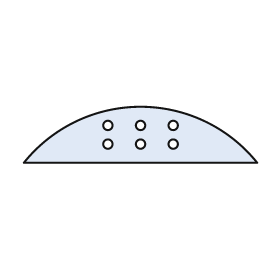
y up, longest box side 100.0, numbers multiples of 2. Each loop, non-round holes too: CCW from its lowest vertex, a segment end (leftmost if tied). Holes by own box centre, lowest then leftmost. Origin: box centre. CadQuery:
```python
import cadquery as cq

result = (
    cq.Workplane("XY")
    .moveTo(-50.0, -12.0)
    .lineTo(50.0, -12.0)
    .threePointArc((0.0, 12.0), (-50.0, -12.0))
    .close()
    .moveTo(-14.0, -4.0)
    .circle(2.0)
    .moveTo(0.0, -4.0)
    .circle(2.0)
    .moveTo(14.0, -4.0)
    .circle(2.0)
    .moveTo(-14.0, 4.0)
    .circle(2.0)
    .moveTo(0.0, 4.0)
    .circle(2.0)
    .moveTo(14.0, 4.0)
    .circle(2.0)
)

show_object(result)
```